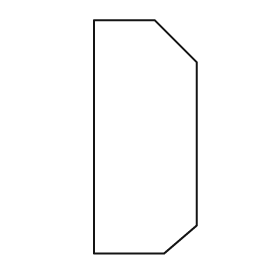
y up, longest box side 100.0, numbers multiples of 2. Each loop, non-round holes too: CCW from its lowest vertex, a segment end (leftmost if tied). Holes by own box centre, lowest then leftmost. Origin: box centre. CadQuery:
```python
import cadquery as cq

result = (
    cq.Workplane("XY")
    .moveTo(-22.0, -50.0)
    .lineTo(8.0, -50.0)
    .lineTo(22.0, -38.0)
    .lineTo(22.0, 32.0)
    .lineTo(4.0, 50.0)
    .lineTo(-22.0, 50.0)
    .close()
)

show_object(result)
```